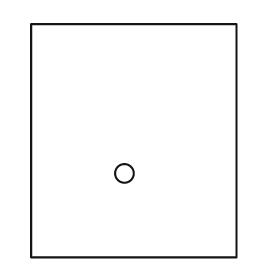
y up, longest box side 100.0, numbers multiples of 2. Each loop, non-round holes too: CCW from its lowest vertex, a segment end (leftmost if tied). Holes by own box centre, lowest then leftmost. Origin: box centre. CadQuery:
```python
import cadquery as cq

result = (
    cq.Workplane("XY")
    .moveTo(-44.0, -50.0)
    .lineTo(44.0, -50.0)
    .lineTo(44.0, 50.0)
    .lineTo(-44.0, 50.0)
    .close()
    .moveTo(-4.0, -14.0)
    .circle(4.0)
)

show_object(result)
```